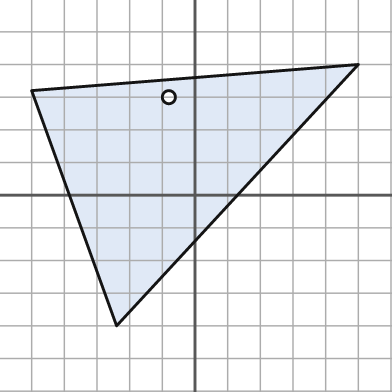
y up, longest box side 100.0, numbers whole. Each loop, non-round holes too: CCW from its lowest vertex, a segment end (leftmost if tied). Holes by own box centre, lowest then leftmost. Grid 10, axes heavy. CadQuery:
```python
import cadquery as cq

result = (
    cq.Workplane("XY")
    .moveTo(-24.0, -40.0)
    .lineTo(50.0, 40.0)
    .lineTo(-50.0, 32.0)
    .close()
    .moveTo(-8.0, 30.0)
    .circle(2.0)
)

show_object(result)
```